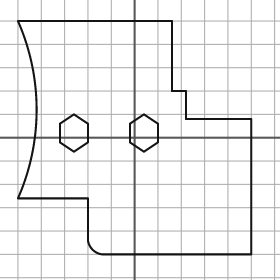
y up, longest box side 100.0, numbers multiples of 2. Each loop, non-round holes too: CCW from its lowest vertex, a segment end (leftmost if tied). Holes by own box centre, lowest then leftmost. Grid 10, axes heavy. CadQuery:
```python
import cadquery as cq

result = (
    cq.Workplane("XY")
    .moveTo(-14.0, -50.0)
    .lineTo(50.0, -50.0)
    .lineTo(50.0, 8.0)
    .lineTo(22.0, 8.0)
    .lineTo(22.0, 20.0)
    .lineTo(16.0, 20.0)
    .lineTo(16.0, 50.0)
    .lineTo(-50.0, 50.0)
    .threePointArc((-42.0, 12.0), (-50.0, -26.0))
    .lineTo(-20.0, -26.0)
    .lineTo(-20.0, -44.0)
    .threePointArc((-18.0, -48.0), (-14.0, -50.0))
    .close()
    .moveTo(-26.0, -6.0)
    .lineTo(-20.0, -2.0)
    .lineTo(-20.0, 6.0)
    .lineTo(-26.0, 10.0)
    .lineTo(-32.0, 6.0)
    .lineTo(-32.0, -2.0)
    .close()
    .moveTo(4.0, -6.0)
    .lineTo(10.0, -2.0)
    .lineTo(10.0, 6.0)
    .lineTo(4.0, 10.0)
    .lineTo(-2.0, 6.0)
    .lineTo(-2.0, -2.0)
    .close()
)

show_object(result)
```